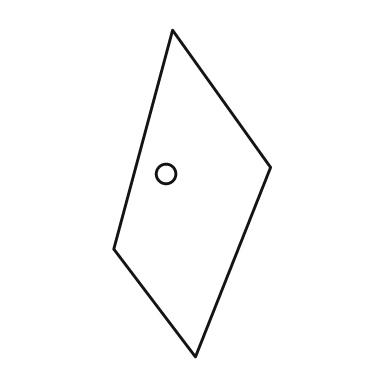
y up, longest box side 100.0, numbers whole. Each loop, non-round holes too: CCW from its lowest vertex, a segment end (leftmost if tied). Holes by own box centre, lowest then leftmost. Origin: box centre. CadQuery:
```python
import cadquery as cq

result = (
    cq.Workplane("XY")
    .moveTo(1.0, -50.0)
    .lineTo(24.0, 8.0)
    .lineTo(-6.0, 50.0)
    .lineTo(-24.0, -17.0)
    .close()
    .moveTo(-8.0, 6.0)
    .circle(3.0)
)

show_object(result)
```